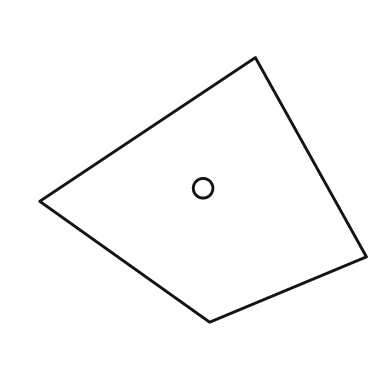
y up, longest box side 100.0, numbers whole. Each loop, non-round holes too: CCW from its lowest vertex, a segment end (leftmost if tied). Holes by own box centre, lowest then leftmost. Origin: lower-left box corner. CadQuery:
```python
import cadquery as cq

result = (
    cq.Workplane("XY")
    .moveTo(52.0, 0.0)
    .lineTo(100.0, 20.0)
    .lineTo(66.0, 81.0)
    .lineTo(0.0, 37.0)
    .close()
    .moveTo(50.0, 41.0)
    .circle(3.0)
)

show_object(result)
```